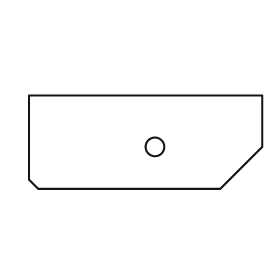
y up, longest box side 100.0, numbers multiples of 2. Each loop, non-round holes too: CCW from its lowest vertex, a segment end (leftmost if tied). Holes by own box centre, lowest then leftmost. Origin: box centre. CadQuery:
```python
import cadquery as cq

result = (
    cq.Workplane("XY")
    .moveTo(-46.0, -20.0)
    .lineTo(32.0, -20.0)
    .lineTo(50.0, -2.0)
    .lineTo(50.0, 20.0)
    .lineTo(-50.0, 20.0)
    .lineTo(-50.0, -16.0)
    .close()
    .moveTo(4.0, -2.0)
    .circle(4.0)
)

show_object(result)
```